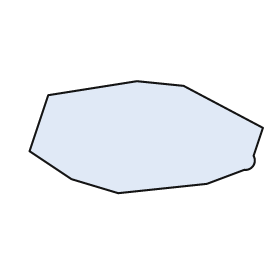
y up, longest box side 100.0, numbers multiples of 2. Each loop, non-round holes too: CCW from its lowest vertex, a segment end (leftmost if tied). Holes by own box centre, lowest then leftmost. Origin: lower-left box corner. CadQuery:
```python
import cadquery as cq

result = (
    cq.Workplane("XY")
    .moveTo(38.0, 0.0)
    .lineTo(76.0, 4.0)
    .lineTo(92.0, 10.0)
    .threePointArc((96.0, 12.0), (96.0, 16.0))
    .lineTo(100.0, 28.0)
    .lineTo(66.0, 46.0)
    .lineTo(46.0, 48.0)
    .lineTo(8.0, 42.0)
    .lineTo(0.0, 18.0)
    .lineTo(18.0, 6.0)
    .close()
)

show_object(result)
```